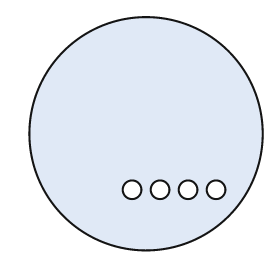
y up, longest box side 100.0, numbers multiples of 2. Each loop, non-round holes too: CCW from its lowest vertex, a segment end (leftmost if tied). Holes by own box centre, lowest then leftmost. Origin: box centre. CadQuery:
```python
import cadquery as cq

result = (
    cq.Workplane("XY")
    .moveTo(0.0, 0.0)
    .circle(50.0)
    .moveTo(-6.0, -24.0)
    .circle(4.0)
    .moveTo(6.0, -24.0)
    .circle(4.0)
    .moveTo(18.0, -24.0)
    .circle(4.0)
    .moveTo(30.0, -24.0)
    .circle(4.0)
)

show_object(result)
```